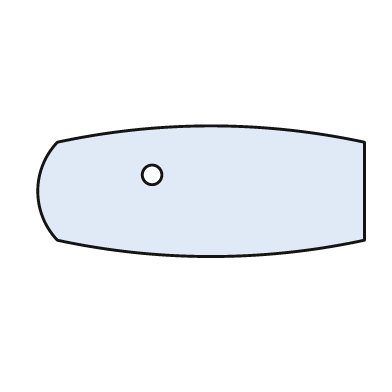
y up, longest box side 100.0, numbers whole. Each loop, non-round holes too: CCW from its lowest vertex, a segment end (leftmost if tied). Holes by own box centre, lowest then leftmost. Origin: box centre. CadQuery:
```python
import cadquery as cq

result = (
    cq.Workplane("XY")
    .moveTo(-44.0, -15.0)
    .threePointArc((3.0, -20.0), (50.0, -15.0))
    .lineTo(50.0, 15.0)
    .threePointArc((3.0, 20.0), (-44.0, 15.0))
    .threePointArc((-50.0, 0.0), (-44.0, -15.0))
    .close()
    .moveTo(-15.0, 5.0)
    .circle(3.0)
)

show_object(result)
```